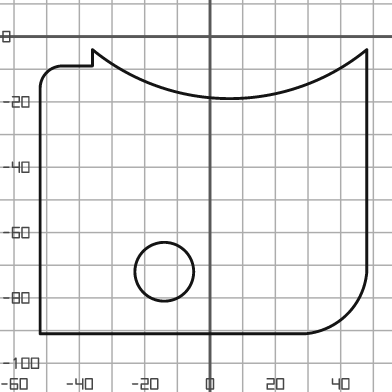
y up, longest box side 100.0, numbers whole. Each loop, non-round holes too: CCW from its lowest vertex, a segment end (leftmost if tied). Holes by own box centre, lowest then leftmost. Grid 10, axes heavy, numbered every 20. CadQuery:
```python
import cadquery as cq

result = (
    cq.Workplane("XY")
    .moveTo(-52.0, -91.0)
    .lineTo(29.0, -91.0)
    .threePointArc((42.0, -85.0), (48.0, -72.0))
    .lineTo(48.0, -4.0)
    .threePointArc((6.0, -19.0), (-36.0, -4.0))
    .lineTo(-36.0, -9.0)
    .lineTo(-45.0, -9.0)
    .threePointArc((-50.0, -11.0), (-52.0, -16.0))
    .close()
    .moveTo(-14.0, -72.0)
    .circle(9.0)
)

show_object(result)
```